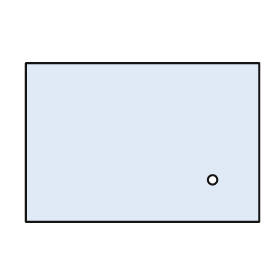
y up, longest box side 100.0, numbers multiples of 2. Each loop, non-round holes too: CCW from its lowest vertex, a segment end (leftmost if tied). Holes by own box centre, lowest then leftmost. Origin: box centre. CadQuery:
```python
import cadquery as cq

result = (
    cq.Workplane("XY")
    .moveTo(-50.0, -34.0)
    .lineTo(50.0, -34.0)
    .lineTo(50.0, 34.0)
    .lineTo(-50.0, 34.0)
    .close()
    .moveTo(30.0, -16.0)
    .circle(2.0)
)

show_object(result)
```